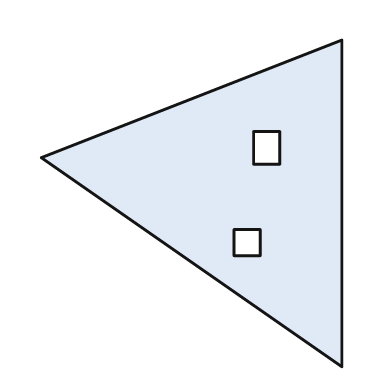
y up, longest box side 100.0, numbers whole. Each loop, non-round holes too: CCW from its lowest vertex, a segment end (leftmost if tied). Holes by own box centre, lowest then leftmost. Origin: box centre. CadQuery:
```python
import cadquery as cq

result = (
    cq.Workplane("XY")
    .moveTo(46.0, -50.0)
    .lineTo(46.0, 50.0)
    .lineTo(-46.0, 14.0)
    .close()
    .moveTo(13.0, -16.0)
    .lineTo(21.0, -16.0)
    .lineTo(21.0, -8.0)
    .lineTo(13.0, -8.0)
    .close()
    .moveTo(19.0, 12.0)
    .lineTo(27.0, 12.0)
    .lineTo(27.0, 22.0)
    .lineTo(19.0, 22.0)
    .close()
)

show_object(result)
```